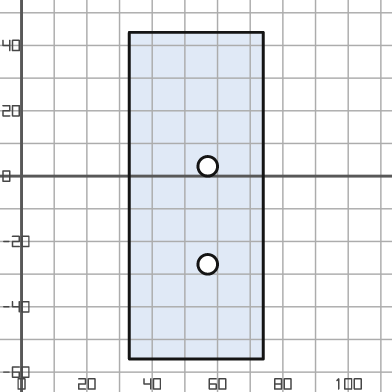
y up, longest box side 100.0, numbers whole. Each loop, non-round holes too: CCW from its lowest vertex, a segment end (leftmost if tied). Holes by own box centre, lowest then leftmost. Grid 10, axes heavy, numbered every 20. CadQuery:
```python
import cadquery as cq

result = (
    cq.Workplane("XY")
    .moveTo(33.0, -56.0)
    .lineTo(74.0, -56.0)
    .lineTo(74.0, 44.0)
    .lineTo(33.0, 44.0)
    .close()
    .moveTo(57.0, -27.0)
    .circle(3.0)
    .moveTo(57.0, 3.0)
    .circle(3.0)
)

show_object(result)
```